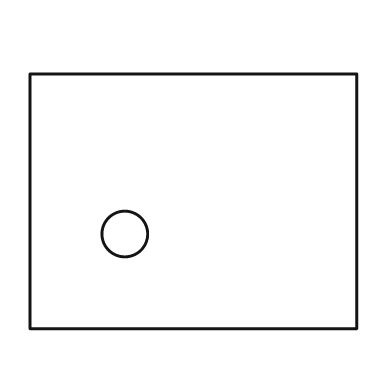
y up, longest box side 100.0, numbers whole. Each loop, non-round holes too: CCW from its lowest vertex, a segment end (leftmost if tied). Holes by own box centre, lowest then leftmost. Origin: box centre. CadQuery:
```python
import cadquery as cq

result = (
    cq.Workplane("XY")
    .moveTo(-50.0, -39.0)
    .lineTo(50.0, -39.0)
    .lineTo(50.0, 39.0)
    .lineTo(-50.0, 39.0)
    .close()
    .moveTo(-21.0, -10.0)
    .circle(7.0)
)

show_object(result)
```